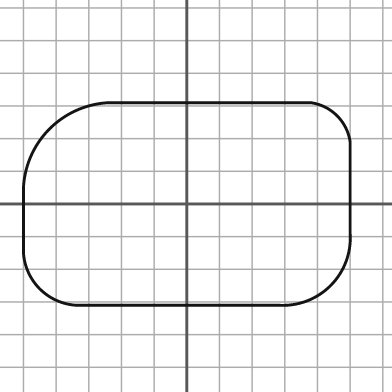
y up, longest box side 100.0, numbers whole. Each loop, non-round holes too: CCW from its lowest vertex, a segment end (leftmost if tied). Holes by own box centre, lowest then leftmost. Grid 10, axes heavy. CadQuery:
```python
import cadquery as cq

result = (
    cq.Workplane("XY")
    .moveTo(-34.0, -31.0)
    .lineTo(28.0, -31.0)
    .threePointArc((44.0, -25.0), (50.0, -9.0))
    .lineTo(50.0, 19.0)
    .threePointArc((46.0, 27.0), (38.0, 31.0))
    .lineTo(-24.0, 31.0)
    .threePointArc((-42.0, 23.0), (-50.0, 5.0))
    .lineTo(-50.0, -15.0)
    .threePointArc((-45.0, -26.0), (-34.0, -31.0))
    .close()
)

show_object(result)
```